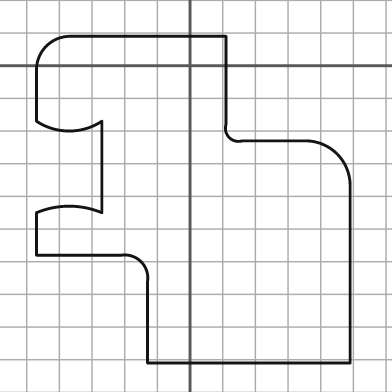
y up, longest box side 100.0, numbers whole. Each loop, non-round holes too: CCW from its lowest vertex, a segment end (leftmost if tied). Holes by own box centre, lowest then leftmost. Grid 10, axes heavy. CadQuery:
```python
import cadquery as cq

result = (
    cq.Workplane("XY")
    .moveTo(-13.0, -91.0)
    .lineTo(49.0, -91.0)
    .lineTo(49.0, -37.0)
    .threePointArc((45.0, -27.0), (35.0, -23.0))
    .lineTo(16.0, -23.0)
    .threePointArc((12.0, -22.0), (11.0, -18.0))
    .lineTo(11.0, 9.0)
    .lineTo(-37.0, 9.0)
    .threePointArc((-44.0, 6.0), (-47.0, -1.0))
    .lineTo(-47.0, -17.0)
    .threePointArc((-37.0, -20.0), (-27.0, -17.0))
    .lineTo(-27.0, -45.0)
    .threePointArc((-37.0, -43.0), (-47.0, -45.0))
    .lineTo(-47.0, -58.0)
    .lineTo(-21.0, -58.0)
    .threePointArc((-15.0, -60.0), (-13.0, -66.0))
    .close()
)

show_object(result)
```